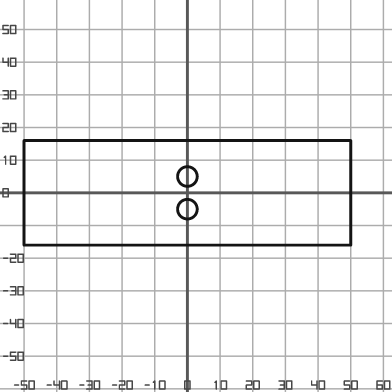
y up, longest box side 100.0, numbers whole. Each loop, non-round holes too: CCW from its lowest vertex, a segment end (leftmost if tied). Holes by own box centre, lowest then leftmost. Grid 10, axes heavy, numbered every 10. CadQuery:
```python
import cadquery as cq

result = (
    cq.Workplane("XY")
    .moveTo(-50.0, -16.0)
    .lineTo(50.0, -16.0)
    .lineTo(50.0, 16.0)
    .lineTo(-50.0, 16.0)
    .close()
    .moveTo(0.0, -5.0)
    .circle(3.0)
    .moveTo(0.0, 5.0)
    .circle(3.0)
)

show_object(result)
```